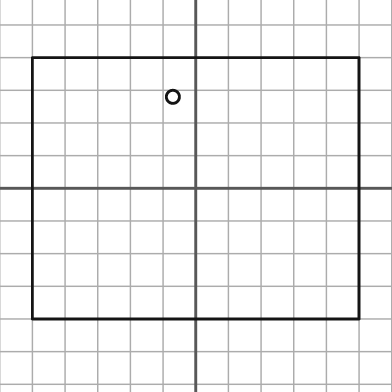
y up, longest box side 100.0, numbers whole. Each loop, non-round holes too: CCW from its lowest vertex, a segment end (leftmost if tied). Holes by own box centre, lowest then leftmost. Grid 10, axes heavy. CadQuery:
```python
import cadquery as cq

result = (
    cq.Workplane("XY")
    .moveTo(-50.0, -40.0)
    .lineTo(50.0, -40.0)
    .lineTo(50.0, 40.0)
    .lineTo(-50.0, 40.0)
    .close()
    .moveTo(-7.0, 28.0)
    .circle(2.0)
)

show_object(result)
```